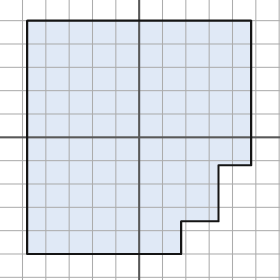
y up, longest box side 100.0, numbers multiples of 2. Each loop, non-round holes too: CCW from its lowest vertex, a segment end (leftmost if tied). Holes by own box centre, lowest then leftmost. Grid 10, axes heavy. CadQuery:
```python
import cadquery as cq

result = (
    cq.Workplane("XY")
    .moveTo(-48.0, -50.0)
    .lineTo(18.0, -50.0)
    .lineTo(18.0, -36.0)
    .lineTo(34.0, -36.0)
    .lineTo(34.0, -12.0)
    .lineTo(48.0, -12.0)
    .lineTo(48.0, 50.0)
    .lineTo(-48.0, 50.0)
    .close()
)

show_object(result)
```